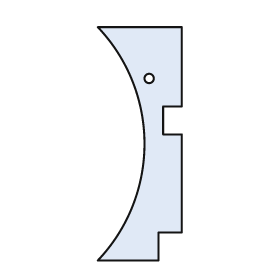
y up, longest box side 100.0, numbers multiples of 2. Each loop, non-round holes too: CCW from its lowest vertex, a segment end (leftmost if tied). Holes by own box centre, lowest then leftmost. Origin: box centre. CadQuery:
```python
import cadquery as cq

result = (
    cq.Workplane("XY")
    .moveTo(-18.0, -50.0)
    .lineTo(8.0, -50.0)
    .lineTo(8.0, -38.0)
    .lineTo(18.0, -38.0)
    .lineTo(18.0, 4.0)
    .lineTo(10.0, 4.0)
    .lineTo(10.0, 16.0)
    .lineTo(18.0, 16.0)
    .lineTo(18.0, 50.0)
    .lineTo(-18.0, 50.0)
    .threePointArc((2.0, 0.0), (-18.0, -50.0))
    .close()
    .moveTo(4.0, 28.0)
    .circle(2.0)
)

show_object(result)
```